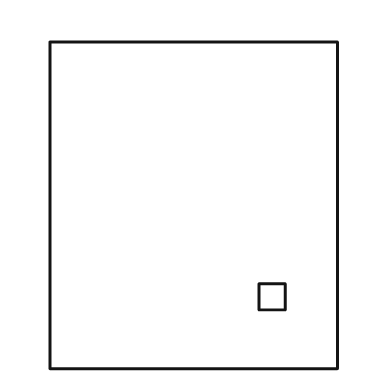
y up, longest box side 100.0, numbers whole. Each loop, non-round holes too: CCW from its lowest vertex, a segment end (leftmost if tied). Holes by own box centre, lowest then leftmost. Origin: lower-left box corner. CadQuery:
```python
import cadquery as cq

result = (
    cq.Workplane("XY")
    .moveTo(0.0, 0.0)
    .lineTo(88.0, 0.0)
    .lineTo(88.0, 100.0)
    .lineTo(0.0, 100.0)
    .close()
    .moveTo(64.0, 18.0)
    .lineTo(72.0, 18.0)
    .lineTo(72.0, 26.0)
    .lineTo(64.0, 26.0)
    .close()
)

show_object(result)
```